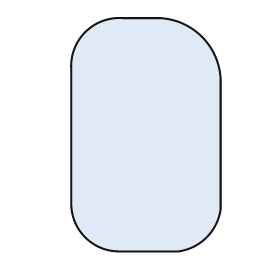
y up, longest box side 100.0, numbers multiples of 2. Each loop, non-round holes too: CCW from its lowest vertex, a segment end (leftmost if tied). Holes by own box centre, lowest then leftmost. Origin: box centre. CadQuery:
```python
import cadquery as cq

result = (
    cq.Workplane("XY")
    .moveTo(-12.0, -50.0)
    .lineTo(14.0, -50.0)
    .threePointArc((26.0, -44.0), (32.0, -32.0))
    .lineTo(32.0, 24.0)
    .threePointArc((24.0, 42.0), (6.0, 50.0))
    .lineTo(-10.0, 50.0)
    .threePointArc((-26.0, 44.0), (-32.0, 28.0))
    .lineTo(-32.0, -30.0)
    .threePointArc((-26.0, -44.0), (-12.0, -50.0))
    .close()
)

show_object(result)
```